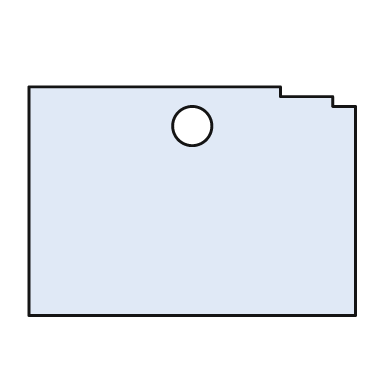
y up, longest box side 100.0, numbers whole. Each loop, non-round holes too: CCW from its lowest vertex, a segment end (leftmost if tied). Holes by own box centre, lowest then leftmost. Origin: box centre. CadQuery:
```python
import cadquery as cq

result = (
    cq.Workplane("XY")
    .moveTo(-50.0, -35.0)
    .lineTo(50.0, -35.0)
    .lineTo(50.0, 29.0)
    .lineTo(43.0, 29.0)
    .lineTo(43.0, 32.0)
    .lineTo(27.0, 32.0)
    .lineTo(27.0, 35.0)
    .lineTo(-50.0, 35.0)
    .close()
    .moveTo(0.0, 23.0)
    .circle(6.0)
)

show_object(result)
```